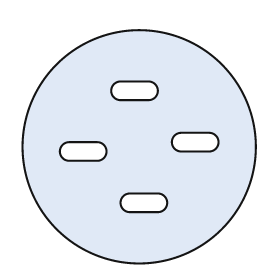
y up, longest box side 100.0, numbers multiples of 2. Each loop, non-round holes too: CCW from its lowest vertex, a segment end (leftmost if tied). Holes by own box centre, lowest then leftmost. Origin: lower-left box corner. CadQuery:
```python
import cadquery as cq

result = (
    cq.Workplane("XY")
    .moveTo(50.0, 50.0)
    .circle(50.0)
    .moveTo(46.0, 22.0)
    .lineTo(58.0, 22.0)
    .threePointArc((62.0, 26.0), (58.0, 30.0))
    .lineTo(46.0, 30.0)
    .threePointArc((42.0, 26.0), (46.0, 22.0))
    .close()
    .moveTo(20.0, 44.0)
    .lineTo(32.0, 44.0)
    .threePointArc((36.0, 48.0), (32.0, 52.0))
    .lineTo(20.0, 52.0)
    .threePointArc((16.0, 48.0), (20.0, 44.0))
    .close()
    .moveTo(68.0, 48.0)
    .lineTo(80.0, 48.0)
    .threePointArc((84.0, 52.0), (80.0, 56.0))
    .lineTo(68.0, 56.0)
    .threePointArc((64.0, 52.0), (68.0, 48.0))
    .close()
    .moveTo(42.0, 70.0)
    .lineTo(54.0, 70.0)
    .threePointArc((58.0, 74.0), (54.0, 78.0))
    .lineTo(42.0, 78.0)
    .threePointArc((38.0, 74.0), (42.0, 70.0))
    .close()
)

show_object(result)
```